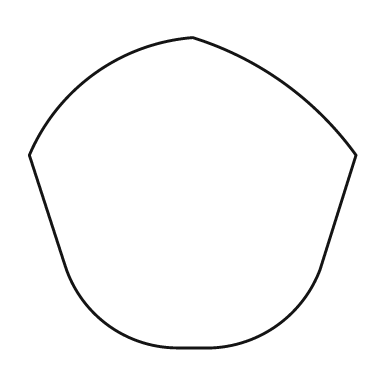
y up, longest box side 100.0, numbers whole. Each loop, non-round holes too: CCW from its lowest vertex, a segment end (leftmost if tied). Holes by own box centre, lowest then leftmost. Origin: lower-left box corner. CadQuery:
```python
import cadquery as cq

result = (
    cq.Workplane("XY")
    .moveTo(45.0, 0.0)
    .lineTo(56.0, 0.0)
    .threePointArc((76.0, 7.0), (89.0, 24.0))
    .lineTo(100.0, 59.0)
    .threePointArc((78.0, 81.0), (50.0, 95.0))
    .threePointArc((20.0, 84.0), (0.0, 59.0))
    .lineTo(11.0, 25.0)
    .threePointArc((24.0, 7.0), (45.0, 0.0))
    .close()
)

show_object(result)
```